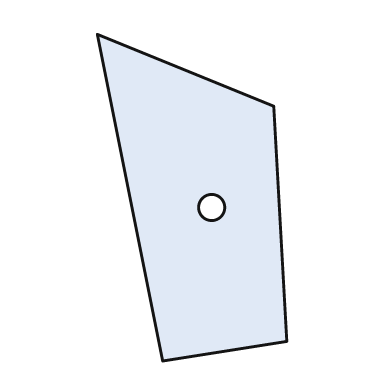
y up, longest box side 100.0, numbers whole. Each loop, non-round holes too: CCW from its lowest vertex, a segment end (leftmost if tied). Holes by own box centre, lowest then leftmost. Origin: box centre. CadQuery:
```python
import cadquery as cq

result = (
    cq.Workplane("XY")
    .moveTo(-9.0, -50.0)
    .lineTo(29.0, -44.0)
    .lineTo(25.0, 28.0)
    .lineTo(-29.0, 50.0)
    .close()
    .moveTo(6.0, -3.0)
    .circle(4.0)
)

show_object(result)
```